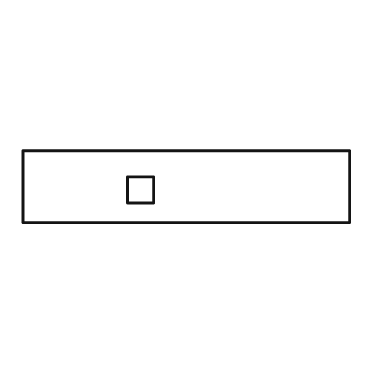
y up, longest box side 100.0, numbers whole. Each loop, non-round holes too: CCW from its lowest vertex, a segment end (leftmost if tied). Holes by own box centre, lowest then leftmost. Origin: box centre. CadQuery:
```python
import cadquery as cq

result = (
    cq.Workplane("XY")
    .moveTo(-50.0, -11.0)
    .lineTo(50.0, -11.0)
    .lineTo(50.0, 11.0)
    .lineTo(-50.0, 11.0)
    .close()
    .moveTo(-18.0, -5.0)
    .lineTo(-10.0, -5.0)
    .lineTo(-10.0, 3.0)
    .lineTo(-18.0, 3.0)
    .close()
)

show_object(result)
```